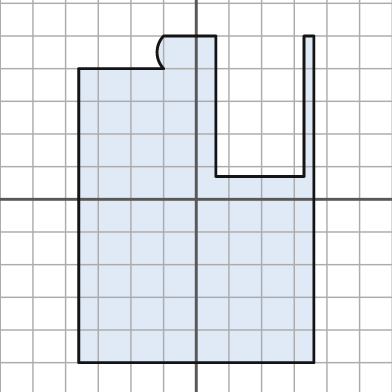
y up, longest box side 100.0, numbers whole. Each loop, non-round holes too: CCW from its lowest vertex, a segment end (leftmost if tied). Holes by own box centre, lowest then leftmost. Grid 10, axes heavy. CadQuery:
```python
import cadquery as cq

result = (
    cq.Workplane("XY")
    .moveTo(-36.0, -50.0)
    .lineTo(36.0, -50.0)
    .lineTo(36.0, 50.0)
    .lineTo(33.0, 50.0)
    .lineTo(33.0, 7.0)
    .lineTo(6.0, 7.0)
    .lineTo(6.0, 50.0)
    .lineTo(-10.0, 50.0)
    .threePointArc((-12.0, 45.0), (-10.0, 40.0))
    .lineTo(-36.0, 40.0)
    .close()
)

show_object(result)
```